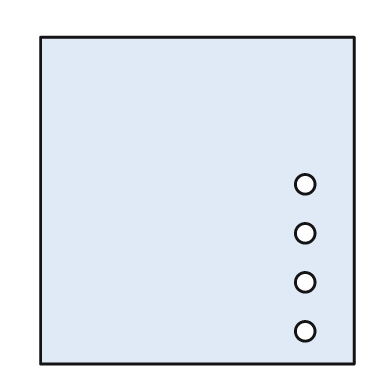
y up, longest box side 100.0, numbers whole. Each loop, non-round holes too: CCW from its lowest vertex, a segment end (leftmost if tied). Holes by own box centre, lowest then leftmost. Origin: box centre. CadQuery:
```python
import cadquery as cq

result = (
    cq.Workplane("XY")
    .moveTo(-48.0, -50.0)
    .lineTo(48.0, -50.0)
    .lineTo(48.0, 50.0)
    .lineTo(-48.0, 50.0)
    .close()
    .moveTo(33.0, -40.0)
    .circle(3.0)
    .moveTo(33.0, -25.0)
    .circle(3.0)
    .moveTo(33.0, -10.0)
    .circle(3.0)
    .moveTo(33.0, 5.0)
    .circle(3.0)
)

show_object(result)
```